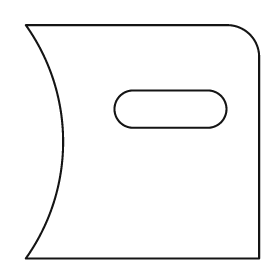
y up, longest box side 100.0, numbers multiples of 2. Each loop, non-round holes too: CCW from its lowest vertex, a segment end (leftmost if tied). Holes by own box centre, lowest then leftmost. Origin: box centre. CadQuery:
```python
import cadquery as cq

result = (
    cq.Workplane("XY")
    .moveTo(-50.0, -50.0)
    .lineTo(50.0, -50.0)
    .lineTo(50.0, 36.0)
    .threePointArc((46.0, 46.0), (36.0, 50.0))
    .lineTo(-50.0, 50.0)
    .threePointArc((-34.0, 0.0), (-50.0, -50.0))
    .close()
    .moveTo(-4.0, 6.0)
    .lineTo(28.0, 6.0)
    .threePointArc((36.0, 14.0), (28.0, 22.0))
    .lineTo(-4.0, 22.0)
    .threePointArc((-12.0, 14.0), (-4.0, 6.0))
    .close()
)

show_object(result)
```